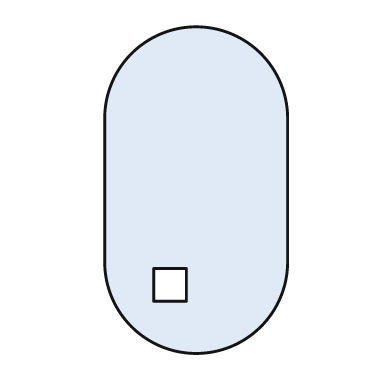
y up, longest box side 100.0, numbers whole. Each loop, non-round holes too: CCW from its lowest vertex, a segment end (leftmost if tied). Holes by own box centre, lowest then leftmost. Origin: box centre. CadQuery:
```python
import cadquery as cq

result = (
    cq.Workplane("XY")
    .moveTo(-28.0, -22.0)
    .threePointArc((0.0, -50.0), (28.0, -22.0))
    .lineTo(28.0, 22.0)
    .threePointArc((0.0, 50.0), (-28.0, 22.0))
    .close()
    .moveTo(-13.0, -34.0)
    .lineTo(-3.0, -34.0)
    .lineTo(-3.0, -24.0)
    .lineTo(-13.0, -24.0)
    .close()
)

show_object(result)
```